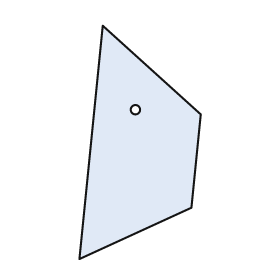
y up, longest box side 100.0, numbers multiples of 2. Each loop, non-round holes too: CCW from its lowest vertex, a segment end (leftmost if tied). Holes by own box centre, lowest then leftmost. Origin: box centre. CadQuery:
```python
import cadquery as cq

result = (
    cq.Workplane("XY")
    .moveTo(-26.0, -50.0)
    .lineTo(22.0, -28.0)
    .lineTo(26.0, 12.0)
    .lineTo(-16.0, 50.0)
    .close()
    .moveTo(-2.0, 14.0)
    .circle(2.0)
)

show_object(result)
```